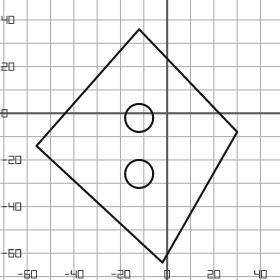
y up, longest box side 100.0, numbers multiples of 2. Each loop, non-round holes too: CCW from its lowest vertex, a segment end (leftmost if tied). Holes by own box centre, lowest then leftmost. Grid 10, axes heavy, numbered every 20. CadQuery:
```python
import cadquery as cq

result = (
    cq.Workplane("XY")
    .moveTo(-2.0, -64.0)
    .lineTo(30.0, -8.0)
    .lineTo(-12.0, 36.0)
    .lineTo(-56.0, -14.0)
    .close()
    .moveTo(-12.0, -26.0)
    .circle(6.0)
    .moveTo(-12.0, -2.0)
    .circle(6.0)
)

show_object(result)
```